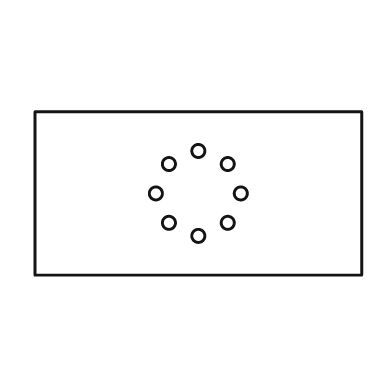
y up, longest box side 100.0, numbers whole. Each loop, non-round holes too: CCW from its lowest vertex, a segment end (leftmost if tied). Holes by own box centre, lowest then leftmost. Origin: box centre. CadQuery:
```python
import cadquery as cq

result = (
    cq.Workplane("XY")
    .moveTo(-50.0, -25.0)
    .lineTo(50.0, -25.0)
    .lineTo(50.0, 25.0)
    .lineTo(-50.0, 25.0)
    .close()
    .moveTo(0.0, -13.0)
    .circle(2.0)
    .moveTo(-9.0, -9.0)
    .circle(2.0)
    .moveTo(9.0, -9.0)
    .circle(2.0)
    .moveTo(-13.0, 0.0)
    .circle(2.0)
    .moveTo(13.0, 0.0)
    .circle(2.0)
    .moveTo(-9.0, 9.0)
    .circle(2.0)
    .moveTo(9.0, 9.0)
    .circle(2.0)
    .moveTo(0.0, 13.0)
    .circle(2.0)
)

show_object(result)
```